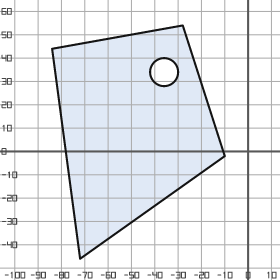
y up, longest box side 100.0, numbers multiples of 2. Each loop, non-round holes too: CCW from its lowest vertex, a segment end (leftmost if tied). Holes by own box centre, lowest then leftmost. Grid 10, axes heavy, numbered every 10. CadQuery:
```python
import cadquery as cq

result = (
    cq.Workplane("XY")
    .moveTo(-72.0, -46.0)
    .lineTo(-10.0, -2.0)
    .lineTo(-28.0, 54.0)
    .lineTo(-84.0, 44.0)
    .close()
    .moveTo(-36.0, 34.0)
    .circle(6.0)
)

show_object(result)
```